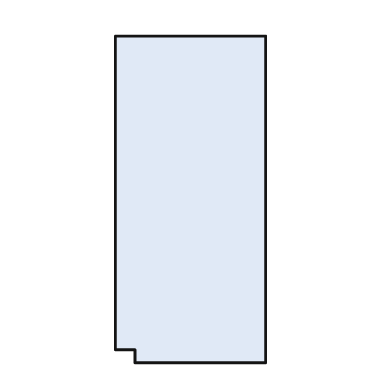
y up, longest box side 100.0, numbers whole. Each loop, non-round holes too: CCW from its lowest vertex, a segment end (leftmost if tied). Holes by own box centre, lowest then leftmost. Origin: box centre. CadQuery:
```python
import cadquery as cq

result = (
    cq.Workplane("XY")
    .moveTo(-17.0, -50.0)
    .lineTo(23.0, -50.0)
    .lineTo(23.0, 50.0)
    .lineTo(-23.0, 50.0)
    .lineTo(-23.0, -46.0)
    .lineTo(-17.0, -46.0)
    .close()
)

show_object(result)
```